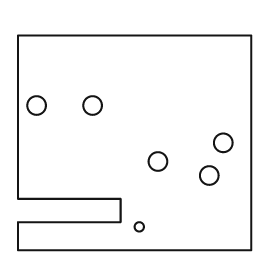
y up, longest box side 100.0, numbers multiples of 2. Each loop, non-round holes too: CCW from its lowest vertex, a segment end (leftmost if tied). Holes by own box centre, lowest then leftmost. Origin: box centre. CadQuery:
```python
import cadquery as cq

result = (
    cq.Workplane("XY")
    .moveTo(-50.0, -46.0)
    .lineTo(50.0, -46.0)
    .lineTo(50.0, 46.0)
    .lineTo(-50.0, 46.0)
    .lineTo(-50.0, -24.0)
    .lineTo(-6.0, -24.0)
    .lineTo(-6.0, -34.0)
    .lineTo(-50.0, -34.0)
    .close()
    .moveTo(2.0, -36.0)
    .circle(2.0)
    .moveTo(32.0, -14.0)
    .circle(4.0)
    .moveTo(10.0, -8.0)
    .circle(4.0)
    .moveTo(38.0, 0.0)
    .circle(4.0)
    .moveTo(-42.0, 16.0)
    .circle(4.0)
    .moveTo(-18.0, 16.0)
    .circle(4.0)
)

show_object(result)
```